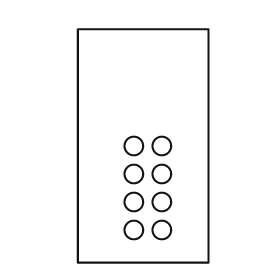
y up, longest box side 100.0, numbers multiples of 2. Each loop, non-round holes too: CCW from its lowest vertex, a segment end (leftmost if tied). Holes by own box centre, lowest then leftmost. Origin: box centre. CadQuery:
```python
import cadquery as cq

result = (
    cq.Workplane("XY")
    .moveTo(-28.0, -50.0)
    .lineTo(28.0, -50.0)
    .lineTo(28.0, 50.0)
    .lineTo(-28.0, 50.0)
    .close()
    .moveTo(-4.0, -36.0)
    .circle(4.0)
    .moveTo(8.0, -36.0)
    .circle(4.0)
    .moveTo(-4.0, -24.0)
    .circle(4.0)
    .moveTo(8.0, -24.0)
    .circle(4.0)
    .moveTo(-4.0, -12.0)
    .circle(4.0)
    .moveTo(8.0, -12.0)
    .circle(4.0)
    .moveTo(-4.0, 0.0)
    .circle(4.0)
    .moveTo(8.0, 0.0)
    .circle(4.0)
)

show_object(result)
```